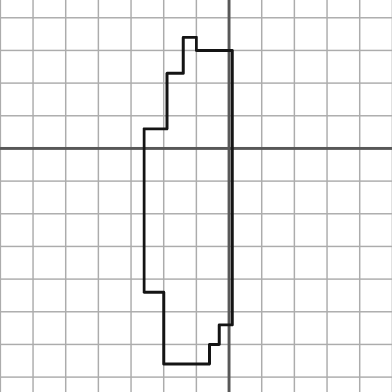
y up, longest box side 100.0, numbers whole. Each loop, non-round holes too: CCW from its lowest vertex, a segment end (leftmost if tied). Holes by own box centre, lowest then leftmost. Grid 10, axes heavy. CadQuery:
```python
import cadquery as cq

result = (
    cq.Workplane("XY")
    .moveTo(-20.0, -66.0)
    .lineTo(-6.0, -66.0)
    .lineTo(-6.0, -60.0)
    .lineTo(-3.0, -60.0)
    .lineTo(-3.0, -54.0)
    .lineTo(1.0, -54.0)
    .lineTo(1.0, 30.0)
    .lineTo(-10.0, 30.0)
    .lineTo(-10.0, 34.0)
    .lineTo(-14.0, 34.0)
    .lineTo(-14.0, 23.0)
    .lineTo(-19.0, 23.0)
    .lineTo(-19.0, 6.0)
    .lineTo(-26.0, 6.0)
    .lineTo(-26.0, -44.0)
    .lineTo(-20.0, -44.0)
    .close()
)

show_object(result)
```